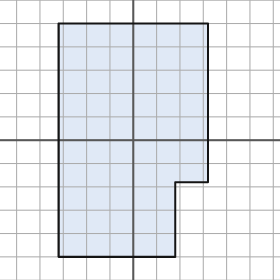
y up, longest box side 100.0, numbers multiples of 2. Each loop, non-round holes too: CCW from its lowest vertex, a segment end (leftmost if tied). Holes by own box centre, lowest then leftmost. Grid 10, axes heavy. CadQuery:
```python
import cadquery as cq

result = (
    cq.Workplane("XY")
    .moveTo(-32.0, -50.0)
    .lineTo(18.0, -50.0)
    .lineTo(18.0, -18.0)
    .lineTo(32.0, -18.0)
    .lineTo(32.0, 50.0)
    .lineTo(-32.0, 50.0)
    .close()
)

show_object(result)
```